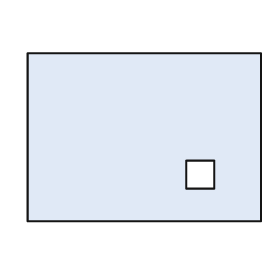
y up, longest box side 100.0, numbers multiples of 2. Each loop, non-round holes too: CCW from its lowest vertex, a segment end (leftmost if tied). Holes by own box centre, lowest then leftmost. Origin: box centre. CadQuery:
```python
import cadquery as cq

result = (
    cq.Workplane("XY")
    .moveTo(-50.0, -36.0)
    .lineTo(50.0, -36.0)
    .lineTo(50.0, 36.0)
    .lineTo(-50.0, 36.0)
    .close()
    .moveTo(18.0, -22.0)
    .lineTo(30.0, -22.0)
    .lineTo(30.0, -10.0)
    .lineTo(18.0, -10.0)
    .close()
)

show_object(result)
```